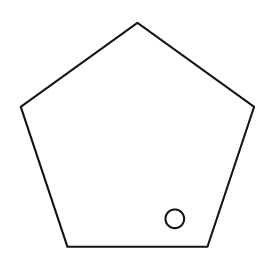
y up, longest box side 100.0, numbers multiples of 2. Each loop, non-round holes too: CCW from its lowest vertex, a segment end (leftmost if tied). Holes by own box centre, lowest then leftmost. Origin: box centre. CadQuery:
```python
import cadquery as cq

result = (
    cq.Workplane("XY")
    .moveTo(-30.0, -48.0)
    .lineTo(30.0, -48.0)
    .lineTo(50.0, 12.0)
    .lineTo(0.0, 48.0)
    .lineTo(-50.0, 12.0)
    .close()
    .moveTo(16.0, -36.0)
    .circle(4.0)
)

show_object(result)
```